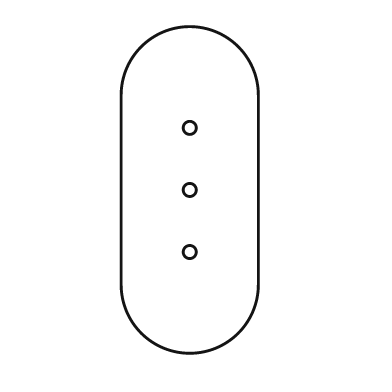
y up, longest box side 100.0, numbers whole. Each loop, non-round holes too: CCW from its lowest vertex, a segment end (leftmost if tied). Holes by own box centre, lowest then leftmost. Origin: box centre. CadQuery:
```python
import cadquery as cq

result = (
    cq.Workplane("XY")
    .moveTo(-21.0, -29.0)
    .threePointArc((0.0, -50.0), (21.0, -29.0))
    .lineTo(21.0, 29.0)
    .threePointArc((0.0, 50.0), (-21.0, 29.0))
    .close()
    .moveTo(0.0, -19.0)
    .circle(2.0)
    .moveTo(0.0, 0.0)
    .circle(2.0)
    .moveTo(0.0, 19.0)
    .circle(2.0)
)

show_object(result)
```